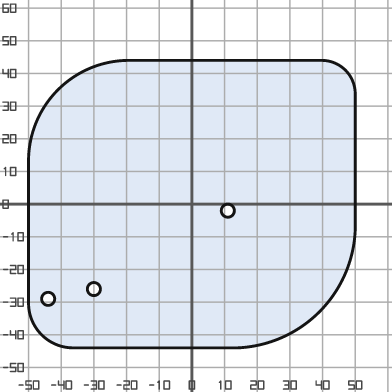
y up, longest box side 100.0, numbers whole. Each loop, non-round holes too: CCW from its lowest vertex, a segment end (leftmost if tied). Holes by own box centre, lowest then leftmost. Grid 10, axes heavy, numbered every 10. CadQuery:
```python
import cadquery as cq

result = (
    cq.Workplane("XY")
    .moveTo(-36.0, -44.0)
    .lineTo(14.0, -44.0)
    .threePointArc((39.0, -33.0), (50.0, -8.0))
    .lineTo(50.0, 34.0)
    .threePointArc((47.0, 41.0), (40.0, 44.0))
    .lineTo(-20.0, 44.0)
    .threePointArc((-41.0, 35.0), (-50.0, 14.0))
    .lineTo(-50.0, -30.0)
    .threePointArc((-46.0, -40.0), (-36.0, -44.0))
    .close()
    .moveTo(-44.0, -29.0)
    .circle(2.0)
    .moveTo(-30.0, -26.0)
    .circle(2.0)
    .moveTo(11.0, -2.0)
    .circle(2.0)
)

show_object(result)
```